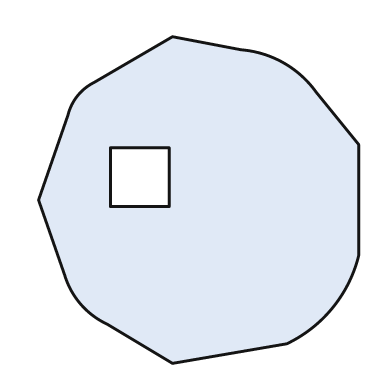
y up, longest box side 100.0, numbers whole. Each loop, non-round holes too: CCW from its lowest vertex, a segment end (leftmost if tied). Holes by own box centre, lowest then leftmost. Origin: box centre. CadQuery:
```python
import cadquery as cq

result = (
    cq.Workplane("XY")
    .moveTo(-8.0, -50.0)
    .lineTo(27.0, -44.0)
    .threePointArc((41.0, -33.0), (49.0, -17.0))
    .lineTo(49.0, 17.0)
    .lineTo(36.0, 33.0)
    .threePointArc((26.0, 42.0), (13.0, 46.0))
    .lineTo(-8.0, 50.0)
    .lineTo(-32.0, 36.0)
    .threePointArc((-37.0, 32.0), (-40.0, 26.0))
    .lineTo(-49.0, 0.0)
    .lineTo(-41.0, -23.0)
    .threePointArc((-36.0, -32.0), (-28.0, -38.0))
    .close()
    .moveTo(-27.0, -2.0)
    .lineTo(-9.0, -2.0)
    .lineTo(-9.0, 16.0)
    .lineTo(-27.0, 16.0)
    .close()
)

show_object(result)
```